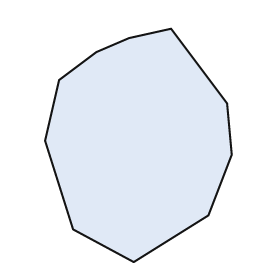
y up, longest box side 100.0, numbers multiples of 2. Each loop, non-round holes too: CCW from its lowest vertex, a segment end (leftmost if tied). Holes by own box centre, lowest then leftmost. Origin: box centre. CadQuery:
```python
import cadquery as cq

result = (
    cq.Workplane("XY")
    .moveTo(-2.0, -50.0)
    .lineTo(30.0, -30.0)
    .lineTo(40.0, -4.0)
    .lineTo(38.0, 18.0)
    .lineTo(14.0, 50.0)
    .lineTo(-4.0, 46.0)
    .lineTo(-18.0, 40.0)
    .lineTo(-34.0, 28.0)
    .lineTo(-40.0, 2.0)
    .lineTo(-28.0, -36.0)
    .close()
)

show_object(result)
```